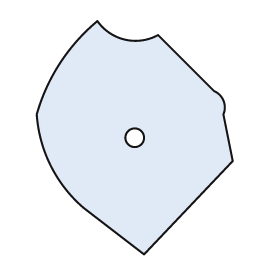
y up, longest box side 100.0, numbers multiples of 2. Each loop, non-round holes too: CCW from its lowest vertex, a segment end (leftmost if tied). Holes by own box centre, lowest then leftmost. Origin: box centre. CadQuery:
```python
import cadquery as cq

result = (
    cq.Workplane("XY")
    .moveTo(4.0, -50.0)
    .lineTo(42.0, -10.0)
    .lineTo(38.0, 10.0)
    .threePointArc((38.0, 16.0), (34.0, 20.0))
    .lineTo(10.0, 44.0)
    .threePointArc((-4.0, 42.0), (-16.0, 50.0))
    .threePointArc((-32.0, 32.0), (-42.0, 10.0))
    .threePointArc((-36.0, -12.0), (-22.0, -30.0))
    .close()
    .moveTo(0.0, 0.0)
    .circle(4.0)
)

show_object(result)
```